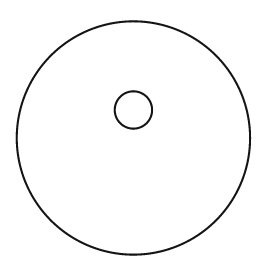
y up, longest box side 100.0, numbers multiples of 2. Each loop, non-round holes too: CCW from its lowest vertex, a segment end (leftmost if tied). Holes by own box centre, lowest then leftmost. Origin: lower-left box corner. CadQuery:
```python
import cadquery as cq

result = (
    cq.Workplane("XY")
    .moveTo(50.0, 50.0)
    .circle(50.0)
    .moveTo(50.0, 62.0)
    .circle(8.0)
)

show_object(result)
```